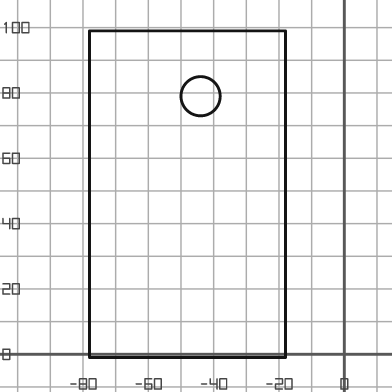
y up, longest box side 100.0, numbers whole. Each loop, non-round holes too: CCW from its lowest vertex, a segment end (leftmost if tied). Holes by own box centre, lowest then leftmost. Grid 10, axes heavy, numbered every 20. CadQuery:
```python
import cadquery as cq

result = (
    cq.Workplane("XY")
    .moveTo(-78.0, -1.0)
    .lineTo(-18.0, -1.0)
    .lineTo(-18.0, 99.0)
    .lineTo(-78.0, 99.0)
    .close()
    .moveTo(-44.0, 79.0)
    .circle(6.0)
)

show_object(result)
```